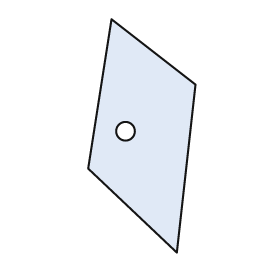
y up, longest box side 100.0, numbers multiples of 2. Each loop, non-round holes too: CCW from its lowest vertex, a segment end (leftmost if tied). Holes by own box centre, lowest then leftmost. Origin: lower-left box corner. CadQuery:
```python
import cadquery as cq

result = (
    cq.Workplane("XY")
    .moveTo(38.0, 0.0)
    .lineTo(46.0, 72.0)
    .lineTo(10.0, 100.0)
    .lineTo(0.0, 36.0)
    .close()
    .moveTo(16.0, 52.0)
    .circle(4.0)
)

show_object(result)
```